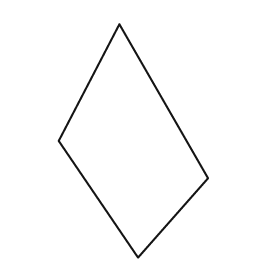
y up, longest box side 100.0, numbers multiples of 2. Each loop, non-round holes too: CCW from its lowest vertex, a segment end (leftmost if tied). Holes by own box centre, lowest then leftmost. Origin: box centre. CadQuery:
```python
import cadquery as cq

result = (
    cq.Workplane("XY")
    .moveTo(2.0, -50.0)
    .lineTo(32.0, -16.0)
    .lineTo(-6.0, 50.0)
    .lineTo(-32.0, 0.0)
    .close()
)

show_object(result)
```